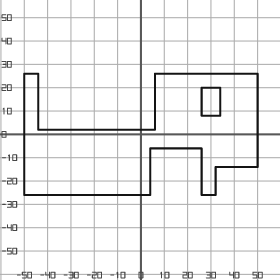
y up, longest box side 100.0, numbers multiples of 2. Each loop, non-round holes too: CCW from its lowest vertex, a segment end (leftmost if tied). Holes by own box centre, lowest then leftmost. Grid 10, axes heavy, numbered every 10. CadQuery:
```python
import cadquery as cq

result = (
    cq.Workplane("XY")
    .moveTo(-50.0, -26.0)
    .lineTo(4.0, -26.0)
    .lineTo(4.0, -6.0)
    .lineTo(26.0, -6.0)
    .lineTo(26.0, -26.0)
    .lineTo(32.0, -26.0)
    .lineTo(32.0, -14.0)
    .lineTo(50.0, -14.0)
    .lineTo(50.0, 26.0)
    .lineTo(6.0, 26.0)
    .lineTo(6.0, 2.0)
    .lineTo(-44.0, 2.0)
    .lineTo(-44.0, 26.0)
    .lineTo(-50.0, 26.0)
    .close()
    .moveTo(26.0, 8.0)
    .lineTo(34.0, 8.0)
    .lineTo(34.0, 20.0)
    .lineTo(26.0, 20.0)
    .close()
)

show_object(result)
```